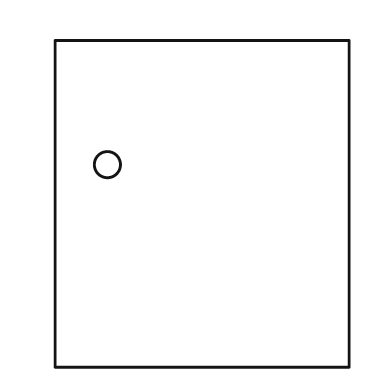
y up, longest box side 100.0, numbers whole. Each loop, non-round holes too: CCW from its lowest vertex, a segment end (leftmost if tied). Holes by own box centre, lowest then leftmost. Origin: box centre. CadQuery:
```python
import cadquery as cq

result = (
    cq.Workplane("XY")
    .moveTo(-45.0, -50.0)
    .lineTo(45.0, -50.0)
    .lineTo(45.0, 50.0)
    .lineTo(-45.0, 50.0)
    .close()
    .moveTo(-29.0, 12.0)
    .circle(4.0)
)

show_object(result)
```